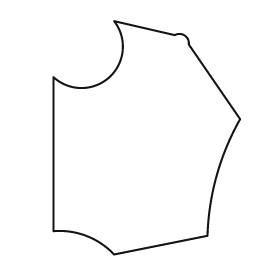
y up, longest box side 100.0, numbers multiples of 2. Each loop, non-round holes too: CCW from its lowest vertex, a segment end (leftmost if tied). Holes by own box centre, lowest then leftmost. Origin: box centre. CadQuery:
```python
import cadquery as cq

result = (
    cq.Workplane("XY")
    .moveTo(-14.0, -50.0)
    .lineTo(26.0, -42.0)
    .threePointArc((30.0, -16.0), (40.0, 8.0))
    .lineTo(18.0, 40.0)
    .threePointArc((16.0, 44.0), (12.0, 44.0))
    .lineTo(-14.0, 50.0)
    .threePointArc((-16.0, 26.0), (-40.0, 26.0))
    .lineTo(-40.0, -40.0)
    .threePointArc((-26.0, -42.0), (-14.0, -50.0))
    .close()
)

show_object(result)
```